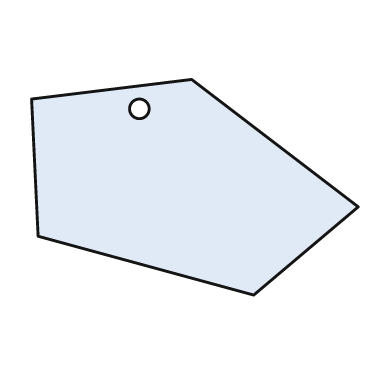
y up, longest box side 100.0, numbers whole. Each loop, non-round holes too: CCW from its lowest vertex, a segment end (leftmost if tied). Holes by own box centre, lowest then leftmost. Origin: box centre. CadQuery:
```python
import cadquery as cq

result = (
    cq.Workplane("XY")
    .moveTo(18.0, -33.0)
    .lineTo(50.0, -6.0)
    .lineTo(-1.0, 33.0)
    .lineTo(-50.0, 27.0)
    .lineTo(-48.0, -15.0)
    .close()
    .moveTo(-17.0, 24.0)
    .circle(3.0)
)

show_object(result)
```